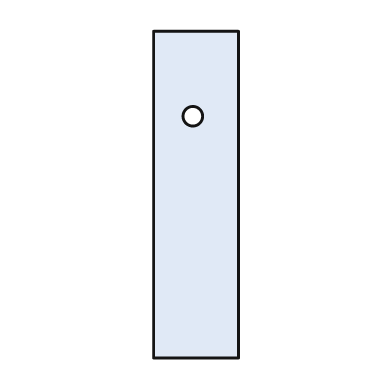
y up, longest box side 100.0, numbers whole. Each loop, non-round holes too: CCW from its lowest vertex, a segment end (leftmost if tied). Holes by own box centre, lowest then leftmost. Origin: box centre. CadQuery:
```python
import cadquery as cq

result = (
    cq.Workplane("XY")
    .moveTo(-13.0, -50.0)
    .lineTo(13.0, -50.0)
    .lineTo(13.0, 50.0)
    .lineTo(-13.0, 50.0)
    .close()
    .moveTo(-1.0, 24.0)
    .circle(3.0)
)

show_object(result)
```